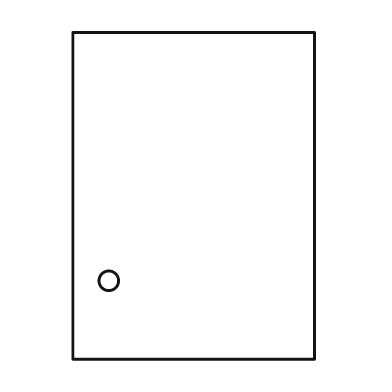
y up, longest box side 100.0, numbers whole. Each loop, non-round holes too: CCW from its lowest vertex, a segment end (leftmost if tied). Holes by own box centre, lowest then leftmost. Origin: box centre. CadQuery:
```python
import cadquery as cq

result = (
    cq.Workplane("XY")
    .moveTo(-37.0, -50.0)
    .lineTo(37.0, -50.0)
    .lineTo(37.0, 50.0)
    .lineTo(-37.0, 50.0)
    .close()
    .moveTo(-26.0, -26.0)
    .circle(3.0)
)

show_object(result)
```